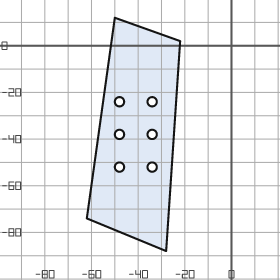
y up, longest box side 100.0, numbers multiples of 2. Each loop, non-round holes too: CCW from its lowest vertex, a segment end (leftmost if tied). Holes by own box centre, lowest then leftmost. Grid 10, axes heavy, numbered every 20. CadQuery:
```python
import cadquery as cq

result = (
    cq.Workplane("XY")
    .moveTo(-28.0, -88.0)
    .lineTo(-22.0, 2.0)
    .lineTo(-50.0, 12.0)
    .lineTo(-62.0, -74.0)
    .close()
    .moveTo(-48.0, -52.0)
    .circle(2.0)
    .moveTo(-34.0, -52.0)
    .circle(2.0)
    .moveTo(-48.0, -38.0)
    .circle(2.0)
    .moveTo(-34.0, -38.0)
    .circle(2.0)
    .moveTo(-48.0, -24.0)
    .circle(2.0)
    .moveTo(-34.0, -24.0)
    .circle(2.0)
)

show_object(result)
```